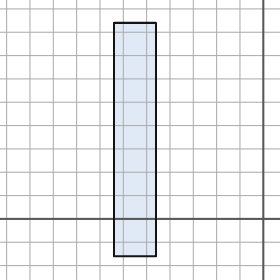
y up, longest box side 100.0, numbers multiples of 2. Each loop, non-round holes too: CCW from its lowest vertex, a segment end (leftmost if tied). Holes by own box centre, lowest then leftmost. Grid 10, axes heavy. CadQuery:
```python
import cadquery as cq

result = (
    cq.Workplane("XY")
    .moveTo(-64.0, -16.0)
    .lineTo(-46.0, -16.0)
    .lineTo(-46.0, 84.0)
    .lineTo(-64.0, 84.0)
    .close()
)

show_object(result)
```